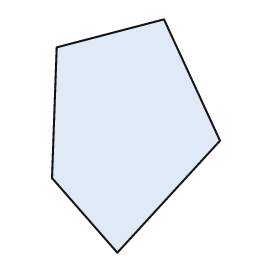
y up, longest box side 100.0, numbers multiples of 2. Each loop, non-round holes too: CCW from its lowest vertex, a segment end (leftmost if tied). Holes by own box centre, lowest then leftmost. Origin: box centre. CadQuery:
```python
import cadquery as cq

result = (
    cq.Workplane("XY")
    .moveTo(-8.0, -50.0)
    .lineTo(36.0, -2.0)
    .lineTo(12.0, 50.0)
    .lineTo(-34.0, 38.0)
    .lineTo(-36.0, -18.0)
    .close()
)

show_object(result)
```